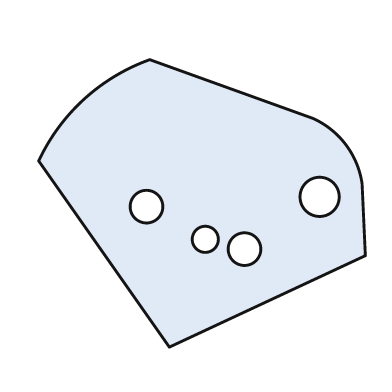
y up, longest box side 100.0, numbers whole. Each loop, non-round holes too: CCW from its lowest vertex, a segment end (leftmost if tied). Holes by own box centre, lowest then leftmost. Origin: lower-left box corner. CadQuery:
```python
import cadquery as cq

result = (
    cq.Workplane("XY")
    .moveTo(40.0, 0.0)
    .lineTo(100.0, 28.0)
    .lineTo(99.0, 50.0)
    .threePointArc((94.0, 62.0), (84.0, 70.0))
    .lineTo(34.0, 88.0)
    .threePointArc((14.0, 76.0), (0.0, 57.0))
    .close()
    .moveTo(63.0, 30.0)
    .circle(5.0)
    .moveTo(51.0, 33.0)
    .circle(4.0)
    .moveTo(33.0, 43.0)
    .circle(5.0)
    .moveTo(86.0, 46.0)
    .circle(6.0)
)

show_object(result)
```